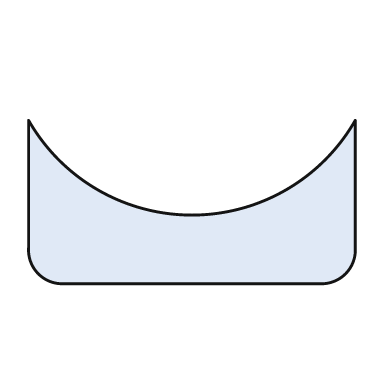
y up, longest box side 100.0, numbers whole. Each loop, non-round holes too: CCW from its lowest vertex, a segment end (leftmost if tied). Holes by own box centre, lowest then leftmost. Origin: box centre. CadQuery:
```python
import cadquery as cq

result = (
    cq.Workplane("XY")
    .moveTo(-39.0, -25.0)
    .lineTo(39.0, -25.0)
    .threePointArc((47.0, -22.0), (50.0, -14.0))
    .lineTo(50.0, 25.0)
    .threePointArc((0.0, -4.0), (-50.0, 25.0))
    .lineTo(-50.0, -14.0)
    .threePointArc((-47.0, -22.0), (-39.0, -25.0))
    .close()
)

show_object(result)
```